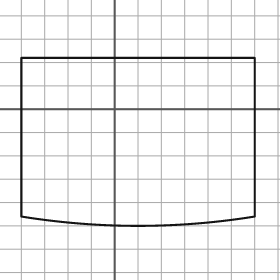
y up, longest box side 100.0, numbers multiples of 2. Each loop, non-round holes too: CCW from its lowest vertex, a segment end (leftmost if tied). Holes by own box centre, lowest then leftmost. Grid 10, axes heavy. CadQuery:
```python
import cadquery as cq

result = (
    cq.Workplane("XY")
    .moveTo(-40.0, -46.0)
    .threePointArc((10.0, -50.0), (60.0, -46.0))
    .lineTo(60.0, 22.0)
    .lineTo(-40.0, 22.0)
    .close()
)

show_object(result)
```